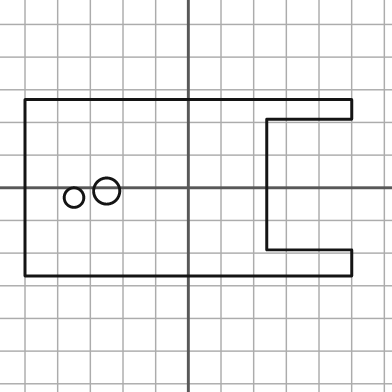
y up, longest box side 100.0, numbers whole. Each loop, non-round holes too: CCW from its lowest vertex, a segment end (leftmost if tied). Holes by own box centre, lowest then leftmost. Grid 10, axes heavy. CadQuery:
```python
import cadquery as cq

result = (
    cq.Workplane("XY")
    .moveTo(-50.0, -27.0)
    .lineTo(50.0, -27.0)
    .lineTo(50.0, -19.0)
    .lineTo(24.0, -19.0)
    .lineTo(24.0, 21.0)
    .lineTo(50.0, 21.0)
    .lineTo(50.0, 27.0)
    .lineTo(-50.0, 27.0)
    .close()
    .moveTo(-35.0, -3.0)
    .circle(3.0)
    .moveTo(-25.0, -1.0)
    .circle(4.0)
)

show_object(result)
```